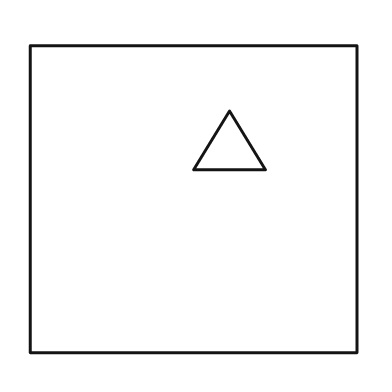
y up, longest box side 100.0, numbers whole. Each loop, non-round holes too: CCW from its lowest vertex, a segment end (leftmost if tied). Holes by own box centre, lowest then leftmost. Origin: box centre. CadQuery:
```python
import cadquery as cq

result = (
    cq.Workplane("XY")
    .moveTo(-50.0, -47.0)
    .lineTo(50.0, -47.0)
    .lineTo(50.0, 47.0)
    .lineTo(-50.0, 47.0)
    .close()
    .moveTo(0.0, 9.0)
    .lineTo(22.0, 9.0)
    .lineTo(11.0, 27.0)
    .close()
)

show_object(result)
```